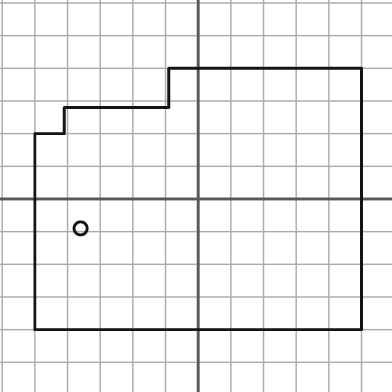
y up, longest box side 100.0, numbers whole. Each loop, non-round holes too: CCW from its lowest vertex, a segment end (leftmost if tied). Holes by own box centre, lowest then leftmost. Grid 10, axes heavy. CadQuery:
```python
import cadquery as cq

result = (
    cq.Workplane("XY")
    .moveTo(-50.0, -40.0)
    .lineTo(50.0, -40.0)
    .lineTo(50.0, 40.0)
    .lineTo(-9.0, 40.0)
    .lineTo(-9.0, 28.0)
    .lineTo(-41.0, 28.0)
    .lineTo(-41.0, 20.0)
    .lineTo(-50.0, 20.0)
    .close()
    .moveTo(-36.0, -9.0)
    .circle(2.0)
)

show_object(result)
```